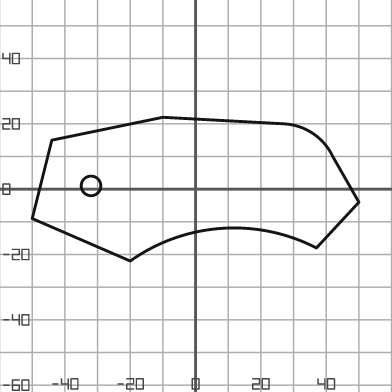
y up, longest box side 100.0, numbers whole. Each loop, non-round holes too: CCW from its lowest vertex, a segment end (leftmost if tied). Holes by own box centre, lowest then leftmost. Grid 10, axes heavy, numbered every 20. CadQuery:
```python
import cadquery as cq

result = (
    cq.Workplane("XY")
    .moveTo(-20.0, -22.0)
    .threePointArc((8.0, -12.0), (37.0, -18.0))
    .lineTo(50.0, -4.0)
    .lineTo(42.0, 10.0)
    .threePointArc((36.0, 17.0), (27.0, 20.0))
    .lineTo(-10.0, 22.0)
    .lineTo(-44.0, 15.0)
    .lineTo(-50.0, -9.0)
    .close()
    .moveTo(-32.0, 1.0)
    .circle(3.0)
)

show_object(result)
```